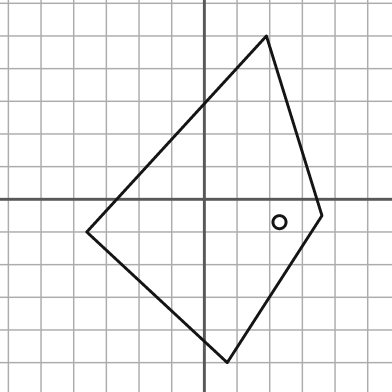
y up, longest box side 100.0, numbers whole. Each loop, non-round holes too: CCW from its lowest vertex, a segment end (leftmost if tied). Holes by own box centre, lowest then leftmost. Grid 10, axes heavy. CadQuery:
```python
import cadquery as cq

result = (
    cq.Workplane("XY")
    .moveTo(7.0, -50.0)
    .lineTo(36.0, -5.0)
    .lineTo(19.0, 50.0)
    .lineTo(-36.0, -10.0)
    .close()
    .moveTo(23.0, -7.0)
    .circle(2.0)
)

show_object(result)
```